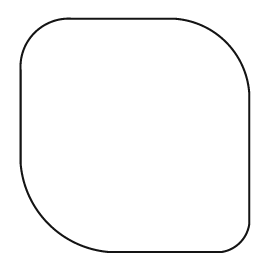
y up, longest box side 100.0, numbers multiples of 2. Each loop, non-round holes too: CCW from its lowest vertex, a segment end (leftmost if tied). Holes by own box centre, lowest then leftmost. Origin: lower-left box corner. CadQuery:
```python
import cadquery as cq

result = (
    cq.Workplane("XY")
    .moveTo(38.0, 0.0)
    .lineTo(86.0, 0.0)
    .threePointArc((94.0, 4.0), (98.0, 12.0))
    .lineTo(98.0, 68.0)
    .threePointArc((88.0, 90.0), (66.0, 100.0))
    .lineTo(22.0, 100.0)
    .threePointArc((6.0, 94.0), (0.0, 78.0))
    .lineTo(0.0, 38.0)
    .threePointArc((12.0, 12.0), (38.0, 0.0))
    .close()
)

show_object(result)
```